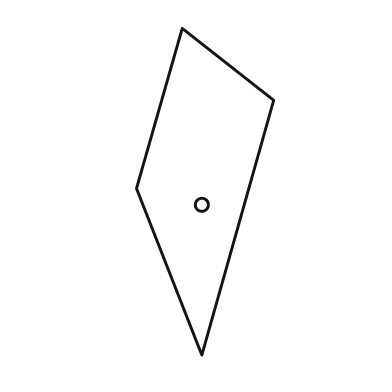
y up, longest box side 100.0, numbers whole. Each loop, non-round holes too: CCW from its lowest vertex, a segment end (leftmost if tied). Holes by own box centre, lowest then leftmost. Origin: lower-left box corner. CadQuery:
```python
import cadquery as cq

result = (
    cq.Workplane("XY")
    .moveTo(20.0, 0.0)
    .lineTo(42.0, 78.0)
    .lineTo(14.0, 100.0)
    .lineTo(0.0, 51.0)
    .close()
    .moveTo(20.0, 46.0)
    .circle(2.0)
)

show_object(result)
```